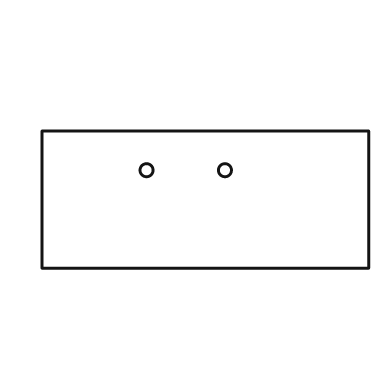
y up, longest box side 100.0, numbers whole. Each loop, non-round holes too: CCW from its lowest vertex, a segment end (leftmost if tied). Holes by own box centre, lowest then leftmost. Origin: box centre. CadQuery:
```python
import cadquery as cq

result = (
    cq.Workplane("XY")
    .moveTo(-50.0, -21.0)
    .lineTo(50.0, -21.0)
    .lineTo(50.0, 21.0)
    .lineTo(-50.0, 21.0)
    .close()
    .moveTo(-18.0, 9.0)
    .circle(2.0)
    .moveTo(6.0, 9.0)
    .circle(2.0)
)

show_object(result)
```